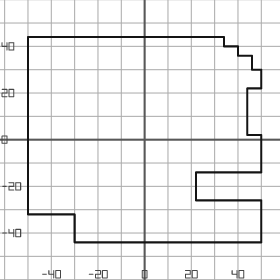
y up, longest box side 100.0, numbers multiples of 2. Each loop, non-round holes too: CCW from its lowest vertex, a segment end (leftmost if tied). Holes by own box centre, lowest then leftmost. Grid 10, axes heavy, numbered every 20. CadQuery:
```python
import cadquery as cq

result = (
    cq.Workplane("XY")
    .moveTo(-30.0, -44.0)
    .lineTo(50.0, -44.0)
    .lineTo(50.0, -26.0)
    .lineTo(22.0, -26.0)
    .lineTo(22.0, -14.0)
    .lineTo(50.0, -14.0)
    .lineTo(50.0, 2.0)
    .lineTo(44.0, 2.0)
    .lineTo(44.0, 22.0)
    .lineTo(50.0, 22.0)
    .lineTo(50.0, 30.0)
    .lineTo(46.0, 30.0)
    .lineTo(46.0, 36.0)
    .lineTo(40.0, 36.0)
    .lineTo(40.0, 40.0)
    .lineTo(34.0, 40.0)
    .lineTo(34.0, 44.0)
    .lineTo(-50.0, 44.0)
    .lineTo(-50.0, -32.0)
    .lineTo(-30.0, -32.0)
    .close()
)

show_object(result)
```